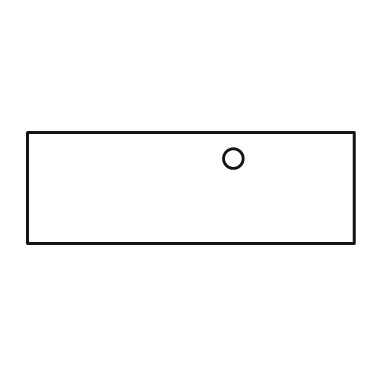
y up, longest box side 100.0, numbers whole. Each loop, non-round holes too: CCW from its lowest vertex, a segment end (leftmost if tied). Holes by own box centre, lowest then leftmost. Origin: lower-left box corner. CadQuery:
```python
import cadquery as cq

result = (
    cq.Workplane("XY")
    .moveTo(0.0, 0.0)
    .lineTo(100.0, 0.0)
    .lineTo(100.0, 34.0)
    .lineTo(0.0, 34.0)
    .close()
    .moveTo(63.0, 26.0)
    .circle(3.0)
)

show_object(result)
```